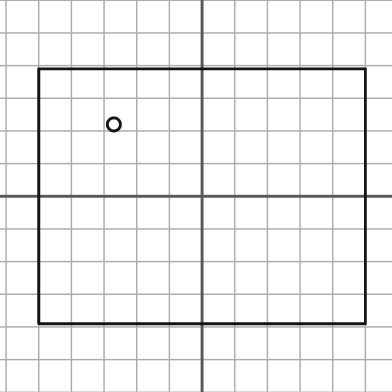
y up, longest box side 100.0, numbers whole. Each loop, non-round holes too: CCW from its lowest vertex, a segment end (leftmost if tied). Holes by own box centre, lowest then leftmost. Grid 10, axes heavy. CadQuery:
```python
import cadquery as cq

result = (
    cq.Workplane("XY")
    .moveTo(-50.0, -39.0)
    .lineTo(50.0, -39.0)
    .lineTo(50.0, 39.0)
    .lineTo(-50.0, 39.0)
    .close()
    .moveTo(-27.0, 22.0)
    .circle(2.0)
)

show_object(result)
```